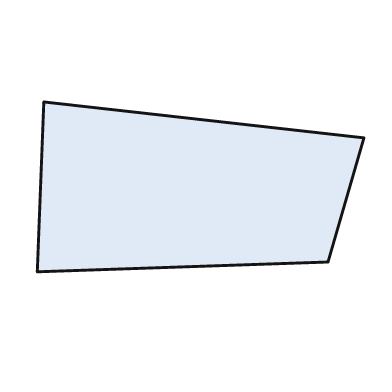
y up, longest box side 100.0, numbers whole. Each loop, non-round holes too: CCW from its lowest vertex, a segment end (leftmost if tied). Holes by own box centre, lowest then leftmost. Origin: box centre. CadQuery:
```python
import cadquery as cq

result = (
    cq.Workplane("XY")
    .moveTo(-50.0, -26.0)
    .lineTo(39.0, -23.0)
    .lineTo(50.0, 15.0)
    .lineTo(-48.0, 26.0)
    .close()
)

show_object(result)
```